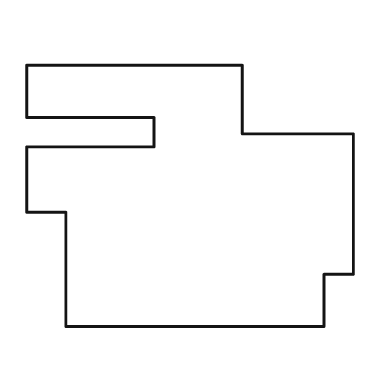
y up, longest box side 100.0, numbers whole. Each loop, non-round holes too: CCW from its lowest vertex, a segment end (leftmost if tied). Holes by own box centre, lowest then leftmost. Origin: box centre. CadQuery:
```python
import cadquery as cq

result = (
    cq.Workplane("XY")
    .moveTo(-38.0, -40.0)
    .lineTo(41.0, -40.0)
    .lineTo(41.0, -24.0)
    .lineTo(50.0, -24.0)
    .lineTo(50.0, 19.0)
    .lineTo(16.0, 19.0)
    .lineTo(16.0, 40.0)
    .lineTo(-50.0, 40.0)
    .lineTo(-50.0, 24.0)
    .lineTo(-11.0, 24.0)
    .lineTo(-11.0, 15.0)
    .lineTo(-50.0, 15.0)
    .lineTo(-50.0, -5.0)
    .lineTo(-38.0, -5.0)
    .close()
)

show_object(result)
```